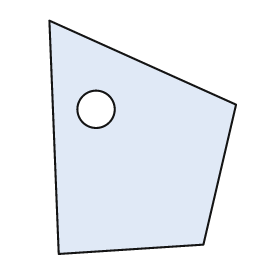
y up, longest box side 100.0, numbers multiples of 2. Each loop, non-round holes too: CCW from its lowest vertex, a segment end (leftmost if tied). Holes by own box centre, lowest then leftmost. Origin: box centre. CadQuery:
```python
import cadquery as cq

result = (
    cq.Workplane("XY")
    .moveTo(-36.0, -50.0)
    .lineTo(26.0, -46.0)
    .lineTo(40.0, 14.0)
    .lineTo(-40.0, 50.0)
    .close()
    .moveTo(-20.0, 12.0)
    .circle(8.0)
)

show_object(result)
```